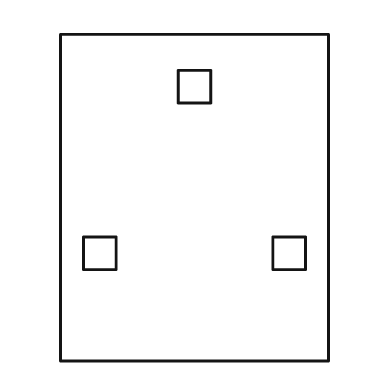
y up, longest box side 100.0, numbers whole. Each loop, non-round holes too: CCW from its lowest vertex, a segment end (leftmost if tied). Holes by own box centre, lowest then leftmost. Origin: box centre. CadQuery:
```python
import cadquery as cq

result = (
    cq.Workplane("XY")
    .moveTo(-41.0, -50.0)
    .lineTo(41.0, -50.0)
    .lineTo(41.0, 50.0)
    .lineTo(-41.0, 50.0)
    .close()
    .moveTo(-34.0, -22.0)
    .lineTo(-24.0, -22.0)
    .lineTo(-24.0, -12.0)
    .lineTo(-34.0, -12.0)
    .close()
    .moveTo(24.0, -22.0)
    .lineTo(34.0, -22.0)
    .lineTo(34.0, -12.0)
    .lineTo(24.0, -12.0)
    .close()
    .moveTo(-5.0, 29.0)
    .lineTo(5.0, 29.0)
    .lineTo(5.0, 39.0)
    .lineTo(-5.0, 39.0)
    .close()
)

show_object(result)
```